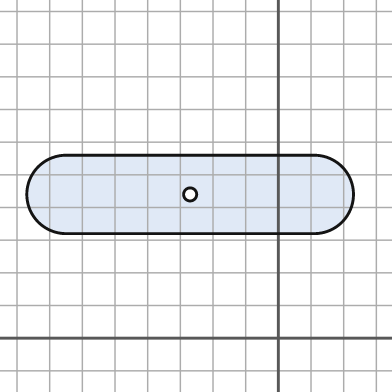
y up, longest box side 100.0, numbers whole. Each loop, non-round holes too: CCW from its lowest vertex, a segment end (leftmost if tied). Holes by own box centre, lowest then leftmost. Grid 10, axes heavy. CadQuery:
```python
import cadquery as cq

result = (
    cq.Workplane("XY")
    .moveTo(-65.0, 32.0)
    .lineTo(11.0, 32.0)
    .threePointArc((23.0, 44.0), (11.0, 56.0))
    .lineTo(-65.0, 56.0)
    .threePointArc((-77.0, 44.0), (-65.0, 32.0))
    .close()
    .moveTo(-27.0, 44.0)
    .circle(2.0)
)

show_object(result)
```